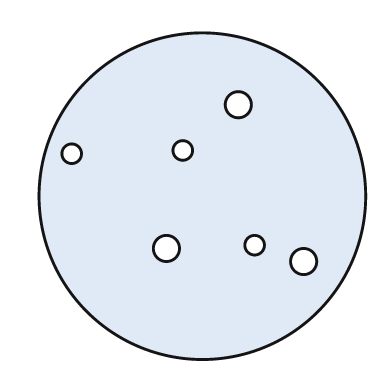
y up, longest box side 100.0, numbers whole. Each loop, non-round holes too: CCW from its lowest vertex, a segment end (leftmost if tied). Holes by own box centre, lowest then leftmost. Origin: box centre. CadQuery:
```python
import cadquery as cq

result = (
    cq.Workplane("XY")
    .moveTo(0.0, 0.0)
    .circle(50.0)
    .moveTo(31.0, -20.0)
    .circle(4.0)
    .moveTo(-11.0, -16.0)
    .circle(4.0)
    .moveTo(16.0, -15.0)
    .circle(3.0)
    .moveTo(-40.0, 13.0)
    .circle(3.0)
    .moveTo(-6.0, 14.0)
    .circle(3.0)
    .moveTo(11.0, 28.0)
    .circle(4.0)
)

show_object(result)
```